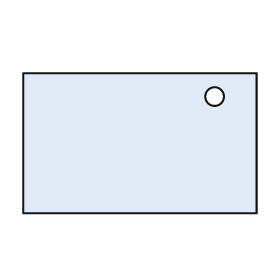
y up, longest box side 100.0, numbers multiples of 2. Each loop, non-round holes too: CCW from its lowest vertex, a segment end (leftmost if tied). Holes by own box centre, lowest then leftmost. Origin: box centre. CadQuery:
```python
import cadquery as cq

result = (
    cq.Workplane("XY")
    .moveTo(-50.0, -30.0)
    .lineTo(50.0, -30.0)
    .lineTo(50.0, 30.0)
    .lineTo(-50.0, 30.0)
    .close()
    .moveTo(32.0, 20.0)
    .circle(4.0)
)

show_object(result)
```